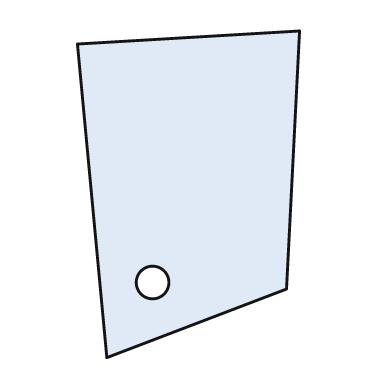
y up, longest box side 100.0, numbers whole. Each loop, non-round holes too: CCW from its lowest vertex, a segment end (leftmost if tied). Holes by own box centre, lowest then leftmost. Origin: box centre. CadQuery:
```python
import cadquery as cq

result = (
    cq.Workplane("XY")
    .moveTo(-25.0, -50.0)
    .lineTo(30.0, -29.0)
    .lineTo(34.0, 50.0)
    .lineTo(-34.0, 46.0)
    .close()
    .moveTo(-11.0, -27.0)
    .circle(5.0)
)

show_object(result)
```